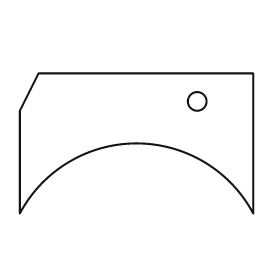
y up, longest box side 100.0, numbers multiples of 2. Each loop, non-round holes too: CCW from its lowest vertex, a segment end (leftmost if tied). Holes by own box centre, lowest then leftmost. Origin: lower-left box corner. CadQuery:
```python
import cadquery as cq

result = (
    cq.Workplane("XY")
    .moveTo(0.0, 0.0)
    .threePointArc((50.0, 30.0), (100.0, 0.0))
    .lineTo(100.0, 60.0)
    .lineTo(8.0, 60.0)
    .lineTo(0.0, 44.0)
    .close()
    .moveTo(76.0, 48.0)
    .circle(4.0)
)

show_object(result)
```